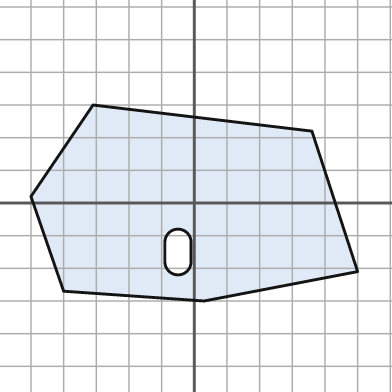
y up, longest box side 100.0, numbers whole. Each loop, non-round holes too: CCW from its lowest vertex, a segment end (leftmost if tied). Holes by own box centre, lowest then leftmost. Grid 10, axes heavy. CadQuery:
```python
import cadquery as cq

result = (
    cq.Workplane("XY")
    .moveTo(3.0, -30.0)
    .lineTo(50.0, -21.0)
    .lineTo(36.0, 22.0)
    .lineTo(-31.0, 30.0)
    .lineTo(-50.0, 2.0)
    .lineTo(-40.0, -27.0)
    .close()
    .moveTo(-9.0, -18.0)
    .threePointArc((-5.0, -22.0), (-1.0, -18.0))
    .lineTo(-1.0, -12.0)
    .threePointArc((-5.0, -8.0), (-9.0, -12.0))
    .close()
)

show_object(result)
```